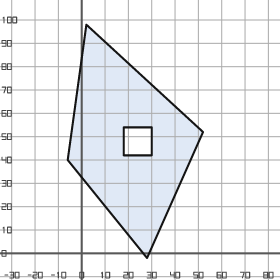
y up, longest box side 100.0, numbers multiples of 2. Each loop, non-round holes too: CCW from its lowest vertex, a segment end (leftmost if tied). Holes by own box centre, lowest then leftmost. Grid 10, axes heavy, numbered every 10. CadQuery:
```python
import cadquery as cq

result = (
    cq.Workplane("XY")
    .moveTo(28.0, -2.0)
    .lineTo(52.0, 52.0)
    .lineTo(2.0, 98.0)
    .lineTo(-6.0, 40.0)
    .close()
    .moveTo(18.0, 42.0)
    .lineTo(30.0, 42.0)
    .lineTo(30.0, 54.0)
    .lineTo(18.0, 54.0)
    .close()
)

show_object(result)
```